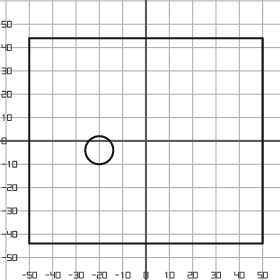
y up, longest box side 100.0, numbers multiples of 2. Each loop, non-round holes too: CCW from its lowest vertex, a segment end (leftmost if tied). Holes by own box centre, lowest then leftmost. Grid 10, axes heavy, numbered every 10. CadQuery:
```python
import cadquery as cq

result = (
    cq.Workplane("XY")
    .moveTo(-50.0, -44.0)
    .lineTo(50.0, -44.0)
    .lineTo(50.0, 44.0)
    .lineTo(-50.0, 44.0)
    .close()
    .moveTo(-20.0, -4.0)
    .circle(6.0)
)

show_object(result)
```